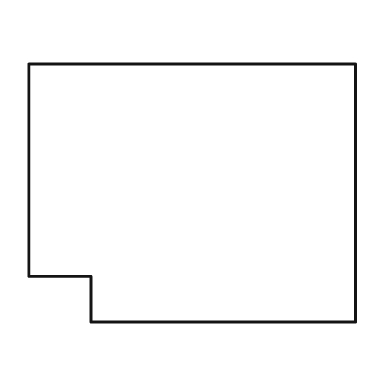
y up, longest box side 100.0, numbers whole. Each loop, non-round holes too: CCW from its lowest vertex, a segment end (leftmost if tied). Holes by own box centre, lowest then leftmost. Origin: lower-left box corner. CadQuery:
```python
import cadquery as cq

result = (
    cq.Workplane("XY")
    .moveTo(19.0, 0.0)
    .lineTo(100.0, 0.0)
    .lineTo(100.0, 79.0)
    .lineTo(0.0, 79.0)
    .lineTo(0.0, 14.0)
    .lineTo(19.0, 14.0)
    .close()
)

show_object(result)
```